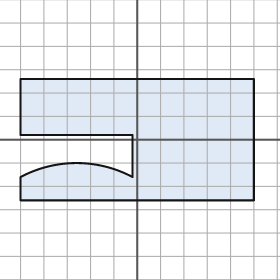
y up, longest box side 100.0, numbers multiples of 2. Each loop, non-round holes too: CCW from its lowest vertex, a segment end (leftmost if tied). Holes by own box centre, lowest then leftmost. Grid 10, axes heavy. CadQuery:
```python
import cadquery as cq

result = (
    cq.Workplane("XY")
    .moveTo(-50.0, -26.0)
    .lineTo(50.0, -26.0)
    .lineTo(50.0, 26.0)
    .lineTo(-50.0, 26.0)
    .lineTo(-50.0, 2.0)
    .lineTo(-2.0, 2.0)
    .lineTo(-2.0, -16.0)
    .threePointArc((-26.0, -10.0), (-50.0, -16.0))
    .close()
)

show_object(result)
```